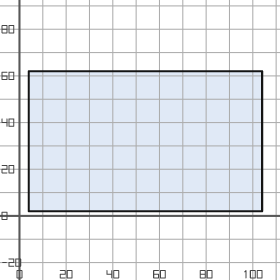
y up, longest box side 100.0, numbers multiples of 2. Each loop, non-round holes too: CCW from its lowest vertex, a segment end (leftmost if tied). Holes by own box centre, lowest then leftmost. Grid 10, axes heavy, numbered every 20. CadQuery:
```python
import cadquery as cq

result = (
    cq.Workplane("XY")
    .moveTo(4.0, 2.0)
    .lineTo(104.0, 2.0)
    .lineTo(104.0, 62.0)
    .lineTo(4.0, 62.0)
    .close()
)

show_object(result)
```